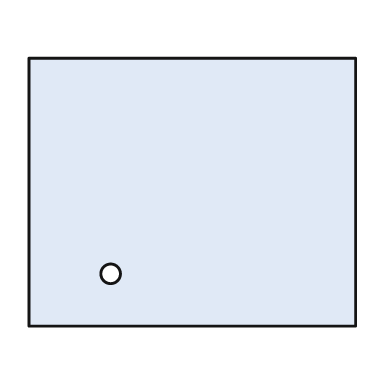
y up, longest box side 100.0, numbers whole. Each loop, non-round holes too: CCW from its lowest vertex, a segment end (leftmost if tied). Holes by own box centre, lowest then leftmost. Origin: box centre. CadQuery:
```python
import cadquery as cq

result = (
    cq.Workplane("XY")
    .moveTo(-50.0, -41.0)
    .lineTo(50.0, -41.0)
    .lineTo(50.0, 41.0)
    .lineTo(-50.0, 41.0)
    .close()
    .moveTo(-25.0, -25.0)
    .circle(3.0)
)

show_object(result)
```